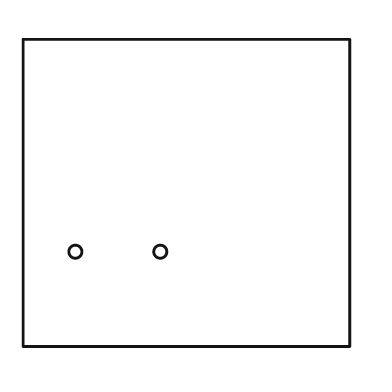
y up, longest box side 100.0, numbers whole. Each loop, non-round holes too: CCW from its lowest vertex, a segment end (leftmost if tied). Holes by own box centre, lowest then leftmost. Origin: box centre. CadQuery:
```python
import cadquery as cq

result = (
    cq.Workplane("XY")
    .moveTo(-50.0, -47.0)
    .lineTo(50.0, -47.0)
    .lineTo(50.0, 47.0)
    .lineTo(-50.0, 47.0)
    .close()
    .moveTo(-34.0, -18.0)
    .circle(2.0)
    .moveTo(-8.0, -18.0)
    .circle(2.0)
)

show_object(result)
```